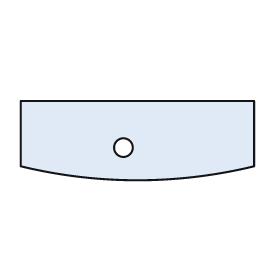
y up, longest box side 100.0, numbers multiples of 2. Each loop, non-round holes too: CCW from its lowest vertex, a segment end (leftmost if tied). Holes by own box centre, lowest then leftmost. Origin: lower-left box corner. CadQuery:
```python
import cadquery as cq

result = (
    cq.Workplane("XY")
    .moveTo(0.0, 6.0)
    .threePointArc((50.0, 0.0), (100.0, 6.0))
    .lineTo(100.0, 34.0)
    .lineTo(0.0, 34.0)
    .close()
    .moveTo(44.0, 14.0)
    .circle(4.0)
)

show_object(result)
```